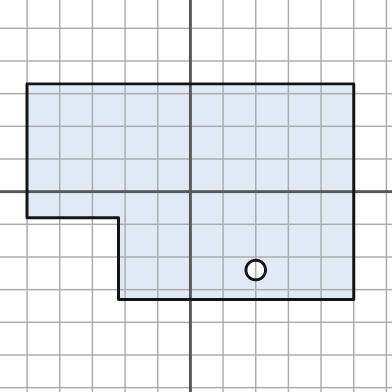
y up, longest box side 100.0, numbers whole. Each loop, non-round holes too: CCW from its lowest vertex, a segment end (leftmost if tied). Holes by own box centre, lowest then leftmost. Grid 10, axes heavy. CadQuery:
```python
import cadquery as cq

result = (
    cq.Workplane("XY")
    .moveTo(-22.0, -33.0)
    .lineTo(50.0, -33.0)
    .lineTo(50.0, 33.0)
    .lineTo(-50.0, 33.0)
    .lineTo(-50.0, -8.0)
    .lineTo(-22.0, -8.0)
    .close()
    .moveTo(20.0, -24.0)
    .circle(3.0)
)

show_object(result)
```